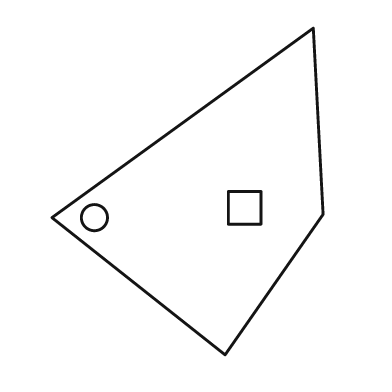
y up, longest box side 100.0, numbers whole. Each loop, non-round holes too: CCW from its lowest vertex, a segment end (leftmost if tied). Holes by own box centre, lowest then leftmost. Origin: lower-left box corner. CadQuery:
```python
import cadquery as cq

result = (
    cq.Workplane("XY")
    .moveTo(53.0, 0.0)
    .lineTo(83.0, 43.0)
    .lineTo(80.0, 100.0)
    .lineTo(0.0, 42.0)
    .close()
    .moveTo(13.0, 42.0)
    .circle(4.0)
    .moveTo(54.0, 40.0)
    .lineTo(64.0, 40.0)
    .lineTo(64.0, 50.0)
    .lineTo(54.0, 50.0)
    .close()
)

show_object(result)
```